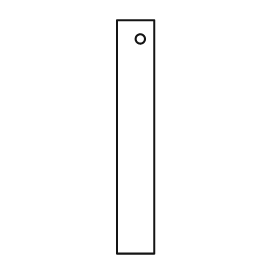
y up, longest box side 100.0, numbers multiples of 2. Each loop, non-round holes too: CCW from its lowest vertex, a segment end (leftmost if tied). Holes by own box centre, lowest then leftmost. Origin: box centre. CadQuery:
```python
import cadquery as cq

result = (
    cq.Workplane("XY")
    .moveTo(-8.0, -50.0)
    .lineTo(8.0, -50.0)
    .lineTo(8.0, 50.0)
    .lineTo(-8.0, 50.0)
    .close()
    .moveTo(2.0, 42.0)
    .circle(2.0)
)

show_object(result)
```